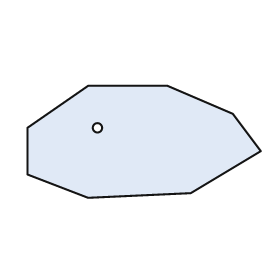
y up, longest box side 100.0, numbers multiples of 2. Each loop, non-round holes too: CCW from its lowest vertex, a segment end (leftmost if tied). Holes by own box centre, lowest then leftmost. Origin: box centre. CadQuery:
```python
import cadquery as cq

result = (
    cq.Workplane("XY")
    .moveTo(-24.0, -24.0)
    .lineTo(20.0, -22.0)
    .lineTo(50.0, -4.0)
    .lineTo(38.0, 12.0)
    .lineTo(10.0, 24.0)
    .lineTo(-24.0, 24.0)
    .lineTo(-50.0, 6.0)
    .lineTo(-50.0, -14.0)
    .close()
    .moveTo(-20.0, 6.0)
    .circle(2.0)
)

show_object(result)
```